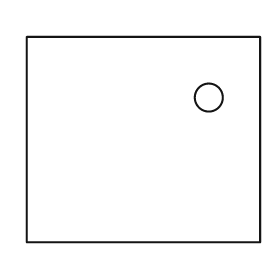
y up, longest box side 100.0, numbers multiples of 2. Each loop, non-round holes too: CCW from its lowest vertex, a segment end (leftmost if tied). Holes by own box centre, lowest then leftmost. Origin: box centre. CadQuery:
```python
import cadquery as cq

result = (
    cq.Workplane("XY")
    .moveTo(-50.0, -44.0)
    .lineTo(50.0, -44.0)
    .lineTo(50.0, 44.0)
    .lineTo(-50.0, 44.0)
    .close()
    .moveTo(28.0, 18.0)
    .circle(6.0)
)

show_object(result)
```